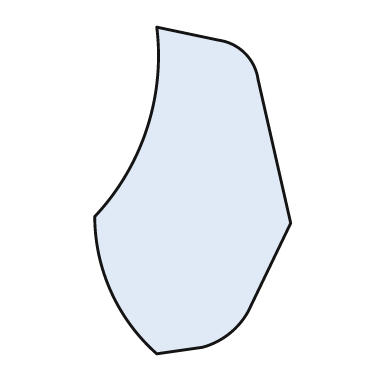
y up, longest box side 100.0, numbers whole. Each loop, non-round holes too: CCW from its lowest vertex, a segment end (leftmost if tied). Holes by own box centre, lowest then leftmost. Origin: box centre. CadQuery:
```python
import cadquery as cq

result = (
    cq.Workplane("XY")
    .moveTo(-11.0, -50.0)
    .lineTo(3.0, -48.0)
    .threePointArc((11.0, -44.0), (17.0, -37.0))
    .lineTo(30.0, -10.0)
    .lineTo(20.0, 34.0)
    .threePointArc((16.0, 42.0), (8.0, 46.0))
    .lineTo(-11.0, 50.0)
    .threePointArc((-14.0, 19.0), (-30.0, -8.0))
    .threePointArc((-25.0, -31.0), (-11.0, -50.0))
    .close()
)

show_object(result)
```